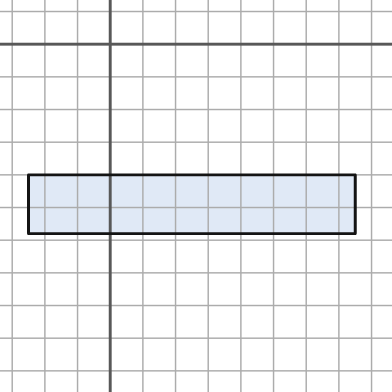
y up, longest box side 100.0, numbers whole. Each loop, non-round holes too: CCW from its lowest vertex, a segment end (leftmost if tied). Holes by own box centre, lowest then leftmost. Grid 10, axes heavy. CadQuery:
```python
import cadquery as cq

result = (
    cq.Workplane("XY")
    .moveTo(-25.0, -58.0)
    .lineTo(75.0, -58.0)
    .lineTo(75.0, -40.0)
    .lineTo(-25.0, -40.0)
    .close()
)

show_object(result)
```